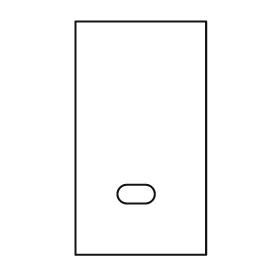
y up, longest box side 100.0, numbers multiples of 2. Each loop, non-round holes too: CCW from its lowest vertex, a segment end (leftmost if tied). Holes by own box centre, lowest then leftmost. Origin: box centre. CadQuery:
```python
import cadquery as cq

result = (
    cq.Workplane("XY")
    .moveTo(-28.0, -50.0)
    .lineTo(28.0, -50.0)
    .lineTo(28.0, 50.0)
    .lineTo(-28.0, 50.0)
    .close()
    .moveTo(-6.0, -28.0)
    .lineTo(2.0, -28.0)
    .threePointArc((6.0, -24.0), (2.0, -20.0))
    .lineTo(-6.0, -20.0)
    .threePointArc((-10.0, -24.0), (-6.0, -28.0))
    .close()
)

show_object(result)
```